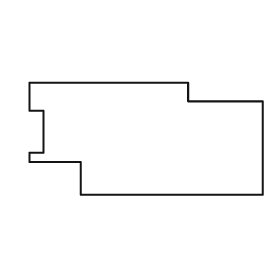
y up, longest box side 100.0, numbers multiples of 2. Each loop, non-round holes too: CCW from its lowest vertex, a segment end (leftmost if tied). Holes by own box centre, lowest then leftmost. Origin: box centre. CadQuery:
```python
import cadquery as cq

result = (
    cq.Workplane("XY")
    .moveTo(-28.0, -24.0)
    .lineTo(50.0, -24.0)
    .lineTo(50.0, 16.0)
    .lineTo(18.0, 16.0)
    .lineTo(18.0, 24.0)
    .lineTo(-50.0, 24.0)
    .lineTo(-50.0, 12.0)
    .lineTo(-44.0, 12.0)
    .lineTo(-44.0, -6.0)
    .lineTo(-50.0, -6.0)
    .lineTo(-50.0, -10.0)
    .lineTo(-28.0, -10.0)
    .close()
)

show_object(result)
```